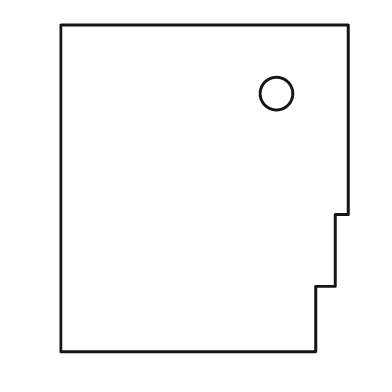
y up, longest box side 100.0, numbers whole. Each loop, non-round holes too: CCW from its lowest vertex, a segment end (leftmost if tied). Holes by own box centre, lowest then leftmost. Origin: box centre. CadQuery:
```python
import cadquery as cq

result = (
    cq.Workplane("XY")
    .moveTo(-44.0, -50.0)
    .lineTo(34.0, -50.0)
    .lineTo(34.0, -30.0)
    .lineTo(40.0, -30.0)
    .lineTo(40.0, -8.0)
    .lineTo(44.0, -8.0)
    .lineTo(44.0, 50.0)
    .lineTo(-44.0, 50.0)
    .close()
    .moveTo(22.0, 29.0)
    .circle(5.0)
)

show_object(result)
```